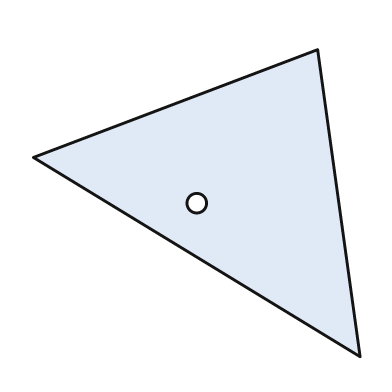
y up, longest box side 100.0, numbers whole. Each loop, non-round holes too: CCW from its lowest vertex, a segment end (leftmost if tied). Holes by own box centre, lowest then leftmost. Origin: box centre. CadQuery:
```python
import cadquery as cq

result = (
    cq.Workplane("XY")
    .moveTo(50.0, -47.0)
    .lineTo(37.0, 47.0)
    .lineTo(-50.0, 14.0)
    .close()
    .moveTo(0.0, 0.0)
    .circle(3.0)
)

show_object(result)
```